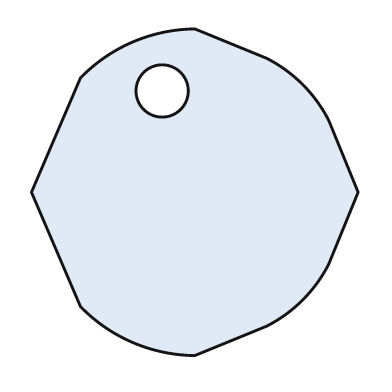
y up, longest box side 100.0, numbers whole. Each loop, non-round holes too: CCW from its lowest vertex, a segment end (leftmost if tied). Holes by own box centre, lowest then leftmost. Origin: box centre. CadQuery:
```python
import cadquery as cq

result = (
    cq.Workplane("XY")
    .moveTo(0.0, -50.0)
    .lineTo(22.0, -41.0)
    .threePointArc((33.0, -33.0), (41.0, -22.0))
    .lineTo(50.0, 0.0)
    .lineTo(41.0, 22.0)
    .threePointArc((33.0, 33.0), (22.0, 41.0))
    .lineTo(0.0, 50.0)
    .threePointArc((-19.0, 46.0), (-35.0, 35.0))
    .lineTo(-50.0, 0.0)
    .lineTo(-35.0, -35.0)
    .threePointArc((-19.0, -46.0), (0.0, -50.0))
    .close()
    .moveTo(-10.0, 31.0)
    .circle(8.0)
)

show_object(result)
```